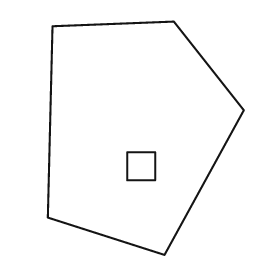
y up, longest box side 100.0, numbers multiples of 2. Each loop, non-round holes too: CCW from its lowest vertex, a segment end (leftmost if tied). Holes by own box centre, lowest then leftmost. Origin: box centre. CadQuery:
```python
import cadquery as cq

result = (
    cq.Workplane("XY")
    .moveTo(8.0, -50.0)
    .lineTo(42.0, 12.0)
    .lineTo(12.0, 50.0)
    .lineTo(-40.0, 48.0)
    .lineTo(-42.0, -34.0)
    .close()
    .moveTo(-8.0, -18.0)
    .lineTo(4.0, -18.0)
    .lineTo(4.0, -6.0)
    .lineTo(-8.0, -6.0)
    .close()
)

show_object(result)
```